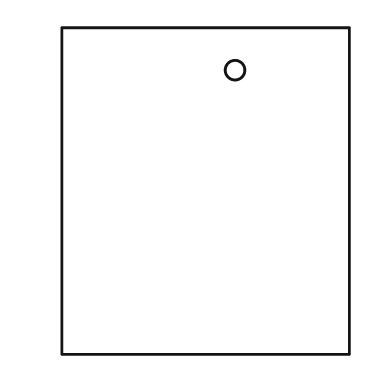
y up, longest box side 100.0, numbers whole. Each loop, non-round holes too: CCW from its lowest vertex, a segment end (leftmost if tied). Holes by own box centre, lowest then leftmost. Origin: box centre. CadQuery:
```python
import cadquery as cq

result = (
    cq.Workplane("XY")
    .moveTo(-44.0, -50.0)
    .lineTo(44.0, -50.0)
    .lineTo(44.0, 50.0)
    .lineTo(-44.0, 50.0)
    .close()
    .moveTo(9.0, 37.0)
    .circle(3.0)
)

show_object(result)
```